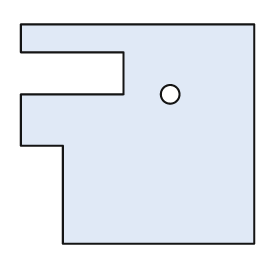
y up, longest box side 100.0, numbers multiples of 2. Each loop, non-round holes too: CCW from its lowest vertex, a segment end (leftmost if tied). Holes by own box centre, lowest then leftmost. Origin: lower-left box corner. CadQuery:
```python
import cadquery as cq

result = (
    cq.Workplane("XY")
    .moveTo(18.0, 0.0)
    .lineTo(100.0, 0.0)
    .lineTo(100.0, 94.0)
    .lineTo(0.0, 94.0)
    .lineTo(0.0, 82.0)
    .lineTo(44.0, 82.0)
    .lineTo(44.0, 64.0)
    .lineTo(0.0, 64.0)
    .lineTo(0.0, 42.0)
    .lineTo(18.0, 42.0)
    .close()
    .moveTo(64.0, 64.0)
    .circle(4.0)
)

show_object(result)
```